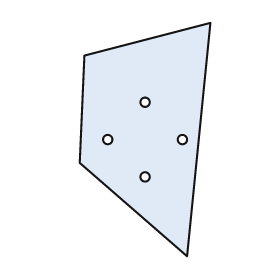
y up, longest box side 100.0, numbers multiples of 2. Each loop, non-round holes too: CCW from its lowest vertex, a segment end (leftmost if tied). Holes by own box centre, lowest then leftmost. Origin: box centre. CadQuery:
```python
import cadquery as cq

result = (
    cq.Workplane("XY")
    .moveTo(18.0, -50.0)
    .lineTo(28.0, 50.0)
    .lineTo(-26.0, 36.0)
    .lineTo(-28.0, -10.0)
    .close()
    .moveTo(0.0, -16.0)
    .circle(2.0)
    .moveTo(-16.0, 0.0)
    .circle(2.0)
    .moveTo(16.0, 0.0)
    .circle(2.0)
    .moveTo(0.0, 16.0)
    .circle(2.0)
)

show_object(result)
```